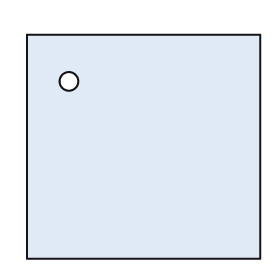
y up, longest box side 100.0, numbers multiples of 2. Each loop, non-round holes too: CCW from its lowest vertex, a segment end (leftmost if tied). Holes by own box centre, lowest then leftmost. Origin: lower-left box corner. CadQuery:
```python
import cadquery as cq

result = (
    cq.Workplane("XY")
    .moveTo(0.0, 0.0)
    .lineTo(100.0, 0.0)
    .lineTo(100.0, 96.0)
    .lineTo(0.0, 96.0)
    .close()
    .moveTo(18.0, 76.0)
    .circle(4.0)
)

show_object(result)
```